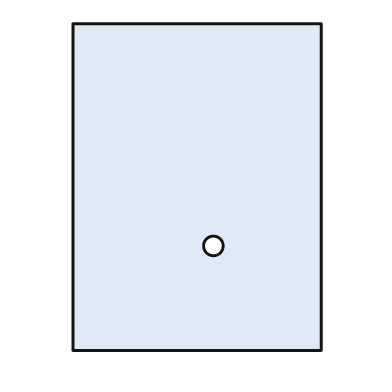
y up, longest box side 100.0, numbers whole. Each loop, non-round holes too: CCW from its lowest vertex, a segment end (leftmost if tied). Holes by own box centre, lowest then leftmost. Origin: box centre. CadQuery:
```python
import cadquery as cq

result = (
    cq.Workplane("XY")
    .moveTo(-38.0, -50.0)
    .lineTo(38.0, -50.0)
    .lineTo(38.0, 50.0)
    .lineTo(-38.0, 50.0)
    .close()
    .moveTo(5.0, -18.0)
    .circle(3.0)
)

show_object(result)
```